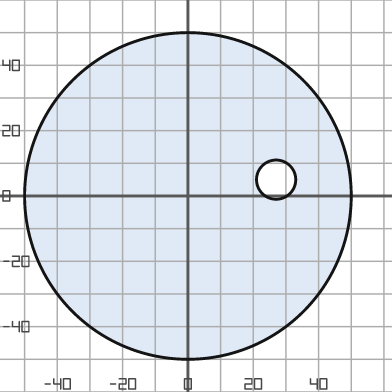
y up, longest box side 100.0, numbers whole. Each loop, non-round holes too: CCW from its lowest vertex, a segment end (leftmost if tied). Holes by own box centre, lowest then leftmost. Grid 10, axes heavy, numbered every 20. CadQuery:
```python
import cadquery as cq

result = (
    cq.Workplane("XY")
    .moveTo(0.0, 0.0)
    .circle(50.0)
    .moveTo(27.0, 5.0)
    .circle(6.0)
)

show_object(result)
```